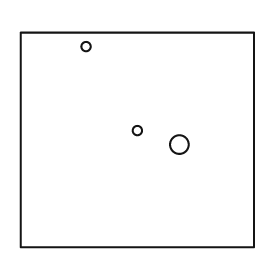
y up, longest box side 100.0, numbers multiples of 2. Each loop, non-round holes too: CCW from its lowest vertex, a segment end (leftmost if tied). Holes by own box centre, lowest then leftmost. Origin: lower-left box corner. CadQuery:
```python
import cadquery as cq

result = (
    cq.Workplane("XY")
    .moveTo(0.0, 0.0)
    .lineTo(100.0, 0.0)
    .lineTo(100.0, 92.0)
    .lineTo(0.0, 92.0)
    .close()
    .moveTo(68.0, 44.0)
    .circle(4.0)
    .moveTo(50.0, 50.0)
    .circle(2.0)
    .moveTo(28.0, 86.0)
    .circle(2.0)
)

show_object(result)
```